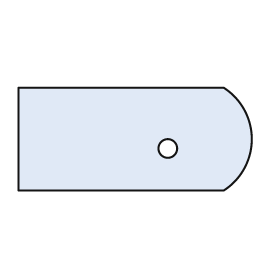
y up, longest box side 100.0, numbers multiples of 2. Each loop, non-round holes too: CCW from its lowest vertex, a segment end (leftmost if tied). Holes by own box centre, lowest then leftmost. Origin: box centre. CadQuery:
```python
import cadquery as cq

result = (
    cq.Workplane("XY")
    .moveTo(-50.0, -22.0)
    .lineTo(38.0, -22.0)
    .threePointArc((50.0, 0.0), (38.0, 22.0))
    .lineTo(-50.0, 22.0)
    .close()
    .moveTo(14.0, -4.0)
    .circle(4.0)
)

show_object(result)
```